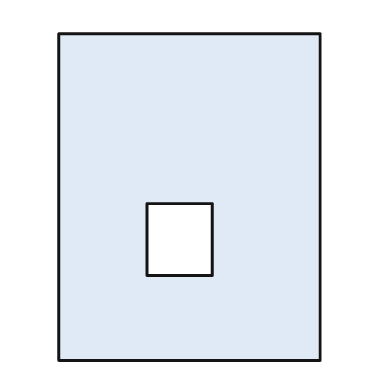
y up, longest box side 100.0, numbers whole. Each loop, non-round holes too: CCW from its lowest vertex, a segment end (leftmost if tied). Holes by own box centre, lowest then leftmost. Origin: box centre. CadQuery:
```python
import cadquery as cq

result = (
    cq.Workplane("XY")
    .moveTo(-40.0, -50.0)
    .lineTo(40.0, -50.0)
    .lineTo(40.0, 50.0)
    .lineTo(-40.0, 50.0)
    .close()
    .moveTo(-13.0, -24.0)
    .lineTo(7.0, -24.0)
    .lineTo(7.0, -2.0)
    .lineTo(-13.0, -2.0)
    .close()
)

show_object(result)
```